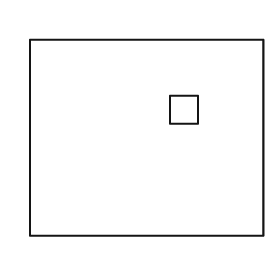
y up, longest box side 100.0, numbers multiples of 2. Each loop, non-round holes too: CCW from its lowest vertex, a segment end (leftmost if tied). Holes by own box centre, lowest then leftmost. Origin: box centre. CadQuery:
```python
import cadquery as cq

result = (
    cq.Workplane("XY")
    .moveTo(-50.0, -42.0)
    .lineTo(50.0, -42.0)
    .lineTo(50.0, 42.0)
    .lineTo(-50.0, 42.0)
    .close()
    .moveTo(10.0, 6.0)
    .lineTo(22.0, 6.0)
    .lineTo(22.0, 18.0)
    .lineTo(10.0, 18.0)
    .close()
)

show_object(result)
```